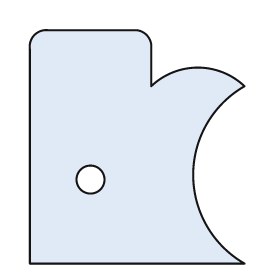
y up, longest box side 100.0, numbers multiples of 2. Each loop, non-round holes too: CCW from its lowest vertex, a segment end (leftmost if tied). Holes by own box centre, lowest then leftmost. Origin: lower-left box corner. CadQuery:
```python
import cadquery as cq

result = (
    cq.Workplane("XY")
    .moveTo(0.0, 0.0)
    .lineTo(92.0, 0.0)
    .threePointArc((70.0, 38.0), (92.0, 76.0))
    .threePointArc((72.0, 84.0), (52.0, 76.0))
    .lineTo(52.0, 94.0)
    .threePointArc((50.0, 98.0), (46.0, 100.0))
    .lineTo(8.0, 100.0)
    .threePointArc((2.0, 98.0), (0.0, 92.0))
    .close()
    .moveTo(26.0, 36.0)
    .circle(6.0)
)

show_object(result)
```